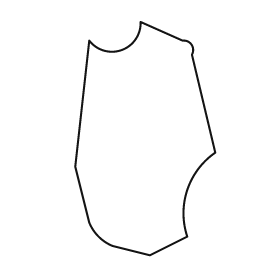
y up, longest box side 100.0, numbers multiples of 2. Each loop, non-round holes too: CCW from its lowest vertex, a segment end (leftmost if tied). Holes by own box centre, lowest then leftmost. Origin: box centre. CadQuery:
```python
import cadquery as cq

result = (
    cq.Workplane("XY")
    .moveTo(2.0, -50.0)
    .lineTo(18.0, -42.0)
    .threePointArc((18.0, -22.0), (30.0, -6.0))
    .lineTo(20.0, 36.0)
    .threePointArc((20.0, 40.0), (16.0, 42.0))
    .lineTo(-2.0, 50.0)
    .threePointArc((-10.0, 38.0), (-24.0, 42.0))
    .lineTo(-30.0, -12.0)
    .lineTo(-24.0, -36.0)
    .threePointArc((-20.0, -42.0), (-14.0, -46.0))
    .close()
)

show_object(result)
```